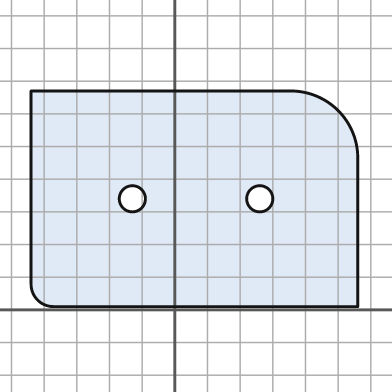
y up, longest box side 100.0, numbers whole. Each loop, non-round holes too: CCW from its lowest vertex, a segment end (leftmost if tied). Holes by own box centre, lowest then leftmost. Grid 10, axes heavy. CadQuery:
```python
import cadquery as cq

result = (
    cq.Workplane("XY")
    .moveTo(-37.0, 1.0)
    .lineTo(56.0, 1.0)
    .lineTo(56.0, 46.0)
    .threePointArc((50.0, 61.0), (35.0, 67.0))
    .lineTo(-44.0, 67.0)
    .lineTo(-44.0, 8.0)
    .threePointArc((-42.0, 3.0), (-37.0, 1.0))
    .close()
    .moveTo(-13.0, 34.0)
    .circle(4.0)
    .moveTo(26.0, 34.0)
    .circle(4.0)
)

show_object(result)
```